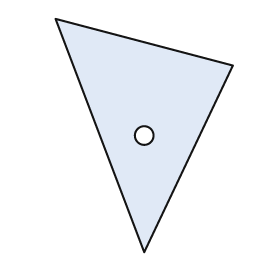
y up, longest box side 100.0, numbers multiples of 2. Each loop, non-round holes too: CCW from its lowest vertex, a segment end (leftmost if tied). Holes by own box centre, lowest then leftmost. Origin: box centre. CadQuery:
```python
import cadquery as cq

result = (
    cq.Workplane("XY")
    .moveTo(0.0, -50.0)
    .lineTo(38.0, 30.0)
    .lineTo(-38.0, 50.0)
    .close()
    .moveTo(0.0, 0.0)
    .circle(4.0)
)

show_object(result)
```